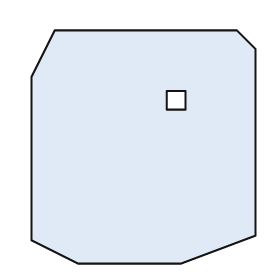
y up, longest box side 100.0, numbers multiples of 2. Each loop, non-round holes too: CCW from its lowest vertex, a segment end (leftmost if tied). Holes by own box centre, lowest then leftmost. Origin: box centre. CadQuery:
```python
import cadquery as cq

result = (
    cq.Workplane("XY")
    .moveTo(-28.0, -50.0)
    .lineTo(16.0, -50.0)
    .lineTo(48.0, -38.0)
    .lineTo(48.0, 42.0)
    .lineTo(40.0, 50.0)
    .lineTo(-38.0, 50.0)
    .lineTo(-48.0, 30.0)
    .lineTo(-48.0, -40.0)
    .close()
    .moveTo(10.0, 16.0)
    .lineTo(18.0, 16.0)
    .lineTo(18.0, 24.0)
    .lineTo(10.0, 24.0)
    .close()
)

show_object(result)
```